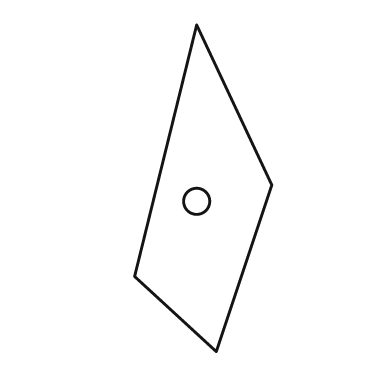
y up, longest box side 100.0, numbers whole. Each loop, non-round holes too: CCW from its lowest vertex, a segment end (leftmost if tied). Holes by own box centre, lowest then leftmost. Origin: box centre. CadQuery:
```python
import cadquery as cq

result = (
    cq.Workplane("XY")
    .moveTo(4.0, -50.0)
    .lineTo(21.0, 1.0)
    .lineTo(-2.0, 50.0)
    .lineTo(-21.0, -27.0)
    .close()
    .moveTo(-2.0, -4.0)
    .circle(4.0)
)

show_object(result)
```